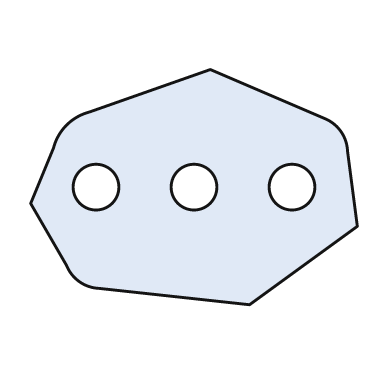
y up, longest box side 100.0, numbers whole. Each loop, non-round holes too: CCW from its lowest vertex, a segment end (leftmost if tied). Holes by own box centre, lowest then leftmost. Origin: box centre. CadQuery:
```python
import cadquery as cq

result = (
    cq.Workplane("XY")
    .moveTo(17.0, -36.0)
    .lineTo(50.0, -12.0)
    .lineTo(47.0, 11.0)
    .threePointArc((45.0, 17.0), (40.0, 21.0))
    .lineTo(5.0, 36.0)
    .lineTo(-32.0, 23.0)
    .threePointArc((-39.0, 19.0), (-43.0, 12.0))
    .lineTo(-50.0, -5.0)
    .lineTo(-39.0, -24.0)
    .threePointArc((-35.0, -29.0), (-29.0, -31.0))
    .close()
    .moveTo(-30.0, 0.0)
    .circle(7.0)
    .moveTo(0.0, 0.0)
    .circle(7.0)
    .moveTo(30.0, 0.0)
    .circle(7.0)
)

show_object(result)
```